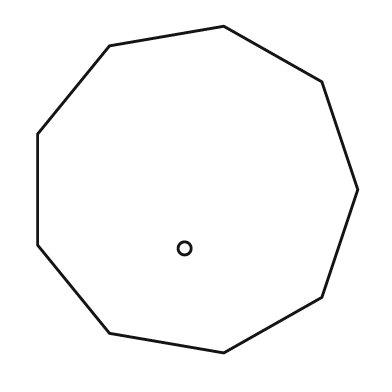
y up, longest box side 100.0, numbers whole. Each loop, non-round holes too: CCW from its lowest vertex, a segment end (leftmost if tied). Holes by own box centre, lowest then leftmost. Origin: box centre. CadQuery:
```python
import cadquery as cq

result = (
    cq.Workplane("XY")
    .moveTo(8.0, -50.0)
    .lineTo(38.0, -33.0)
    .lineTo(49.0, 0.0)
    .lineTo(38.0, 33.0)
    .lineTo(8.0, 50.0)
    .lineTo(-27.0, 44.0)
    .lineTo(-49.0, 17.0)
    .lineTo(-49.0, -17.0)
    .lineTo(-27.0, -44.0)
    .close()
    .moveTo(-4.0, -18.0)
    .circle(2.0)
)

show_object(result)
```